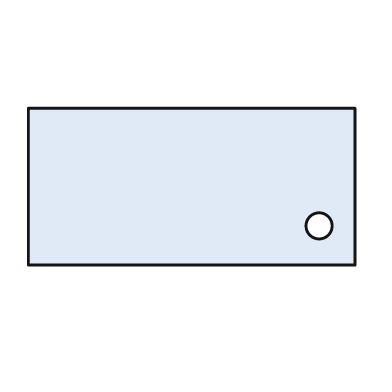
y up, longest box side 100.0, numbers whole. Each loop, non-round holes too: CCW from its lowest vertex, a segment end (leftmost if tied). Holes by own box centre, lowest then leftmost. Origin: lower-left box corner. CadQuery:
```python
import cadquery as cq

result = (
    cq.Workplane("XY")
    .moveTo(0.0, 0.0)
    .lineTo(100.0, 0.0)
    .lineTo(100.0, 48.0)
    .lineTo(0.0, 48.0)
    .close()
    .moveTo(89.0, 12.0)
    .circle(4.0)
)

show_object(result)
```